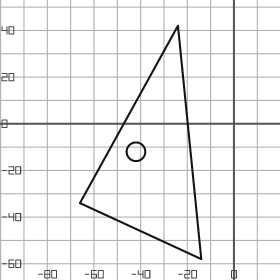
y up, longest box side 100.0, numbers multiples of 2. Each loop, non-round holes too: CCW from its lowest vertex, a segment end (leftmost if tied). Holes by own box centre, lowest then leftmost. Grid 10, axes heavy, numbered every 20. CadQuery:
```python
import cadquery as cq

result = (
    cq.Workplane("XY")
    .moveTo(-14.0, -58.0)
    .lineTo(-24.0, 42.0)
    .lineTo(-66.0, -34.0)
    .close()
    .moveTo(-42.0, -12.0)
    .circle(4.0)
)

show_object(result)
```